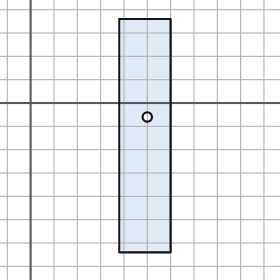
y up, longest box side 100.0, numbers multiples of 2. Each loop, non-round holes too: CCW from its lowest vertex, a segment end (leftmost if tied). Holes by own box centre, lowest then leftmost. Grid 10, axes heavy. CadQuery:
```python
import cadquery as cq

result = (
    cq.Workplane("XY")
    .moveTo(38.0, -64.0)
    .lineTo(60.0, -64.0)
    .lineTo(60.0, 36.0)
    .lineTo(38.0, 36.0)
    .close()
    .moveTo(50.0, -6.0)
    .circle(2.0)
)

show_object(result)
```